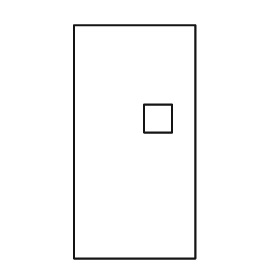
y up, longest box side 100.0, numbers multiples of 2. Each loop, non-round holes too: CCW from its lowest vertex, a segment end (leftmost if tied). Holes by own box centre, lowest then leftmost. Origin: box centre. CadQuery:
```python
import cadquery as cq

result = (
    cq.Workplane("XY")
    .moveTo(-26.0, -50.0)
    .lineTo(26.0, -50.0)
    .lineTo(26.0, 50.0)
    .lineTo(-26.0, 50.0)
    .close()
    .moveTo(4.0, 4.0)
    .lineTo(16.0, 4.0)
    .lineTo(16.0, 16.0)
    .lineTo(4.0, 16.0)
    .close()
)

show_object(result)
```